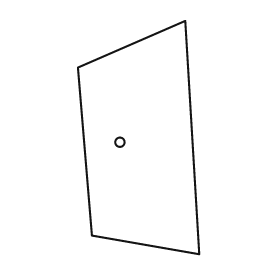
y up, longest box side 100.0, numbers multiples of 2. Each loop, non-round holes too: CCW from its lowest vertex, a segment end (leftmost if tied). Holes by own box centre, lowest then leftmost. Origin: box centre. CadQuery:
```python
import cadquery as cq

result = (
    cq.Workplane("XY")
    .moveTo(26.0, -50.0)
    .lineTo(20.0, 50.0)
    .lineTo(-26.0, 30.0)
    .lineTo(-20.0, -42.0)
    .close()
    .moveTo(-8.0, -2.0)
    .circle(2.0)
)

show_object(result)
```